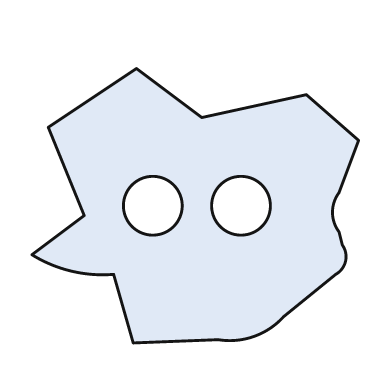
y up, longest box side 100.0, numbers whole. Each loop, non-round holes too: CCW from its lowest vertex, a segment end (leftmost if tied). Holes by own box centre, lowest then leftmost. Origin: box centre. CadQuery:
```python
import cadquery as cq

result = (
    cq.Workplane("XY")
    .moveTo(-19.0, -42.0)
    .lineTo(7.0, -41.0)
    .threePointArc((18.0, -40.0), (27.0, -34.0))
    .lineTo(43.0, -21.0)
    .threePointArc((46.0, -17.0), (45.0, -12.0))
    .lineTo(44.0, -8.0)
    .threePointArc((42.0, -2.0), (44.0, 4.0))
    .lineTo(50.0, 20.0)
    .lineTo(34.0, 34.0)
    .lineTo(2.0, 27.0)
    .lineTo(-18.0, 42.0)
    .lineTo(-45.0, 24.0)
    .lineTo(-34.0, -3.0)
    .lineTo(-50.0, -15.0)
    .threePointArc((-38.0, -20.0), (-25.0, -21.0))
    .close()
    .moveTo(-13.0, 0.0)
    .circle(9.0)
    .moveTo(14.0, 0.0)
    .circle(9.0)
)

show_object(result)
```